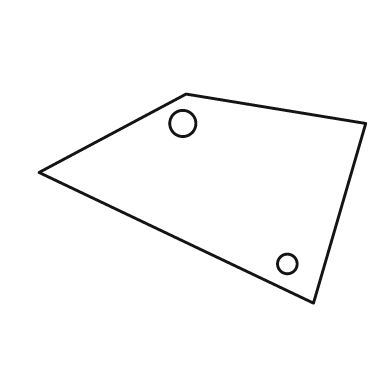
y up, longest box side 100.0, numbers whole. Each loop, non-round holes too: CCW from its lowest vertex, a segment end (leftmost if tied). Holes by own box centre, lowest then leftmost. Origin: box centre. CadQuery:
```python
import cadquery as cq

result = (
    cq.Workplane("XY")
    .moveTo(34.0, -32.0)
    .lineTo(50.0, 23.0)
    .lineTo(-5.0, 32.0)
    .lineTo(-50.0, 8.0)
    .close()
    .moveTo(26.0, -20.0)
    .circle(3.0)
    .moveTo(-6.0, 23.0)
    .circle(4.0)
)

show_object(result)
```